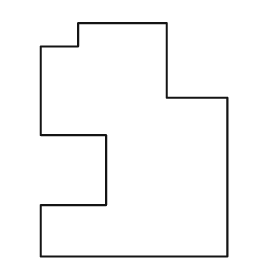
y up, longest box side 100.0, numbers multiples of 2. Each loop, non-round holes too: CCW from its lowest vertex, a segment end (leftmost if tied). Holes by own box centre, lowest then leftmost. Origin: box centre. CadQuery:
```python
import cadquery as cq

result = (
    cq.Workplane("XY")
    .moveTo(-40.0, -50.0)
    .lineTo(40.0, -50.0)
    .lineTo(40.0, 18.0)
    .lineTo(14.0, 18.0)
    .lineTo(14.0, 50.0)
    .lineTo(-24.0, 50.0)
    .lineTo(-24.0, 40.0)
    .lineTo(-40.0, 40.0)
    .lineTo(-40.0, 2.0)
    .lineTo(-12.0, 2.0)
    .lineTo(-12.0, -28.0)
    .lineTo(-40.0, -28.0)
    .close()
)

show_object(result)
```